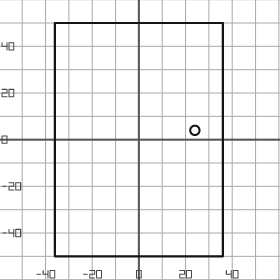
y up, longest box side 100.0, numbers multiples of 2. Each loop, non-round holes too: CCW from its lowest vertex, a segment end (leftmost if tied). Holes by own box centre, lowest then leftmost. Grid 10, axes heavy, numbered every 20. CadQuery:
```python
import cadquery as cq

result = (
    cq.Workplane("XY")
    .moveTo(-36.0, -50.0)
    .lineTo(36.0, -50.0)
    .lineTo(36.0, 50.0)
    .lineTo(-36.0, 50.0)
    .close()
    .moveTo(24.0, 4.0)
    .circle(2.0)
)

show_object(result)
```